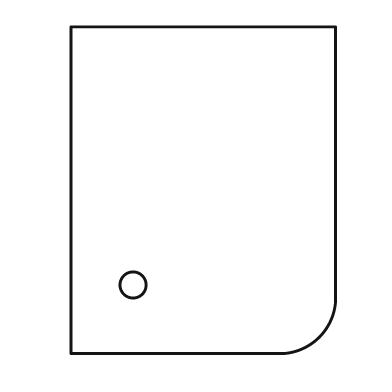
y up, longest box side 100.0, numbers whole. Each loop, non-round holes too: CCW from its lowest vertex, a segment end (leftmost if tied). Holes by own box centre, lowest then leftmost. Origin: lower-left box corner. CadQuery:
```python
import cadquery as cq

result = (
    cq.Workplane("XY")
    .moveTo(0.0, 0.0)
    .lineTo(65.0, 0.0)
    .threePointArc((76.0, 5.0), (81.0, 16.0))
    .lineTo(81.0, 100.0)
    .lineTo(0.0, 100.0)
    .close()
    .moveTo(19.0, 21.0)
    .circle(4.0)
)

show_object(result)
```